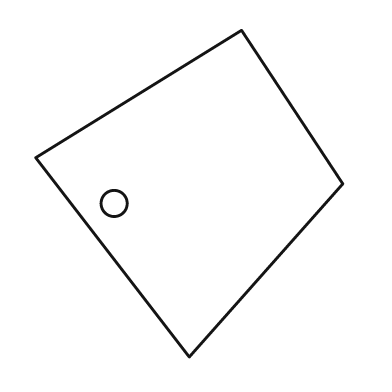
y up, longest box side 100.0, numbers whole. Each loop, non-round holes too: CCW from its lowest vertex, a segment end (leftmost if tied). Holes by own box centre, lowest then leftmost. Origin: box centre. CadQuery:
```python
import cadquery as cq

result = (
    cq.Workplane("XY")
    .moveTo(0.0, -50.0)
    .lineTo(47.0, 3.0)
    .lineTo(16.0, 50.0)
    .lineTo(-47.0, 11.0)
    .close()
    .moveTo(-23.0, -3.0)
    .circle(4.0)
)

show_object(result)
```